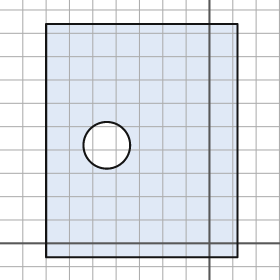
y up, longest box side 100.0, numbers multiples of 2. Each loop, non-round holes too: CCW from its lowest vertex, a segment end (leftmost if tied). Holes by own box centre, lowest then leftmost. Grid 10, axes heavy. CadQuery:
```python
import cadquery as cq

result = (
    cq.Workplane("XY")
    .moveTo(-70.0, -6.0)
    .lineTo(12.0, -6.0)
    .lineTo(12.0, 94.0)
    .lineTo(-70.0, 94.0)
    .close()
    .moveTo(-44.0, 42.0)
    .circle(10.0)
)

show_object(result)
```